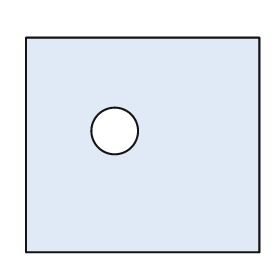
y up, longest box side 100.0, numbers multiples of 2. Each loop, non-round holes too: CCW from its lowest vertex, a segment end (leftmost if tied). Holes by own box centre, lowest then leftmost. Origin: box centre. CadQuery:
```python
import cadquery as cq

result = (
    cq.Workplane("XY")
    .moveTo(-50.0, -46.0)
    .lineTo(50.0, -46.0)
    .lineTo(50.0, 46.0)
    .lineTo(-50.0, 46.0)
    .close()
    .moveTo(-12.0, 6.0)
    .circle(10.0)
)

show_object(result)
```